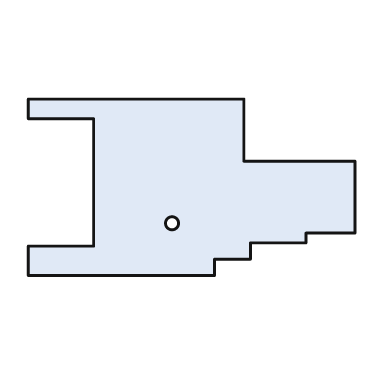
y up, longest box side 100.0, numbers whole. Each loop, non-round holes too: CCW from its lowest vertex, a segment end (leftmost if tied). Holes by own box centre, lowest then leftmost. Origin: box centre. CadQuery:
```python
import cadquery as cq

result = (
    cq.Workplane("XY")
    .moveTo(-50.0, -27.0)
    .lineTo(7.0, -27.0)
    .lineTo(7.0, -22.0)
    .lineTo(18.0, -22.0)
    .lineTo(18.0, -17.0)
    .lineTo(35.0, -17.0)
    .lineTo(35.0, -14.0)
    .lineTo(50.0, -14.0)
    .lineTo(50.0, 8.0)
    .lineTo(16.0, 8.0)
    .lineTo(16.0, 27.0)
    .lineTo(-50.0, 27.0)
    .lineTo(-50.0, 21.0)
    .lineTo(-30.0, 21.0)
    .lineTo(-30.0, -18.0)
    .lineTo(-50.0, -18.0)
    .close()
    .moveTo(-6.0, -11.0)
    .circle(2.0)
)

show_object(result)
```